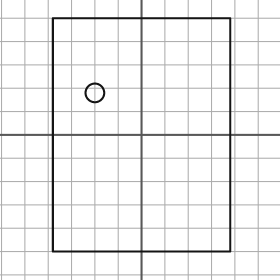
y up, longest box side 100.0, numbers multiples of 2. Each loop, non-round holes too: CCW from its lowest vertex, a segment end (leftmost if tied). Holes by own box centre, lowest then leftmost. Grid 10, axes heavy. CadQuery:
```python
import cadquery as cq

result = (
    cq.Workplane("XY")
    .moveTo(-38.0, -50.0)
    .lineTo(38.0, -50.0)
    .lineTo(38.0, 50.0)
    .lineTo(-38.0, 50.0)
    .close()
    .moveTo(-20.0, 18.0)
    .circle(4.0)
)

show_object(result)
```